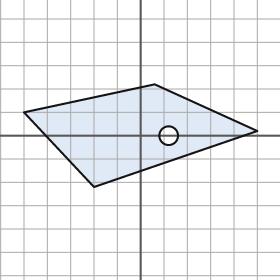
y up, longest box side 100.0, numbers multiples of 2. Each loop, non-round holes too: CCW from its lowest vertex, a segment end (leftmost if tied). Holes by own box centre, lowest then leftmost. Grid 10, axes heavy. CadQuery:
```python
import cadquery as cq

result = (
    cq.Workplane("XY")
    .moveTo(-20.0, -22.0)
    .lineTo(50.0, 2.0)
    .lineTo(6.0, 22.0)
    .lineTo(-50.0, 10.0)
    .close()
    .moveTo(12.0, 0.0)
    .circle(4.0)
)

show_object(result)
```